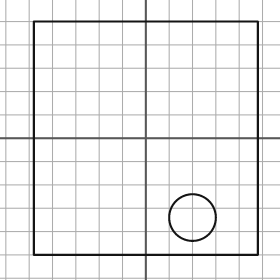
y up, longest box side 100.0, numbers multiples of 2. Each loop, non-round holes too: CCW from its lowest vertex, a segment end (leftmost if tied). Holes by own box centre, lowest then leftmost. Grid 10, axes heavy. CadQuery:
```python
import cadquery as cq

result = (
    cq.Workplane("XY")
    .moveTo(-48.0, -50.0)
    .lineTo(48.0, -50.0)
    .lineTo(48.0, 50.0)
    .lineTo(-48.0, 50.0)
    .close()
    .moveTo(20.0, -34.0)
    .circle(10.0)
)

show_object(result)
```